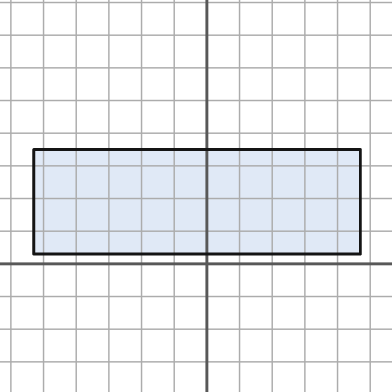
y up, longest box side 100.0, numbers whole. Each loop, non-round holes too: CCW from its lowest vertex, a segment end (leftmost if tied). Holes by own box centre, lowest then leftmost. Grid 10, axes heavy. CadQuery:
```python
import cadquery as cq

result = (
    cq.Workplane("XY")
    .moveTo(-53.0, 3.0)
    .lineTo(47.0, 3.0)
    .lineTo(47.0, 35.0)
    .lineTo(-53.0, 35.0)
    .close()
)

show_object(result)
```